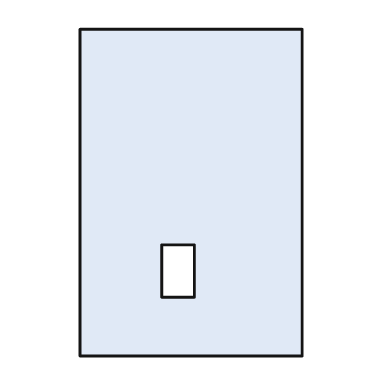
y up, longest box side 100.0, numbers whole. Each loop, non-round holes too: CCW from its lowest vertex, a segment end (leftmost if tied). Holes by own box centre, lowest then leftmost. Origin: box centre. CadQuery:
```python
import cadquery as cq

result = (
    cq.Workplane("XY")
    .moveTo(-34.0, -50.0)
    .lineTo(34.0, -50.0)
    .lineTo(34.0, 50.0)
    .lineTo(-34.0, 50.0)
    .close()
    .moveTo(-9.0, -32.0)
    .lineTo(1.0, -32.0)
    .lineTo(1.0, -16.0)
    .lineTo(-9.0, -16.0)
    .close()
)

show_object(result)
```